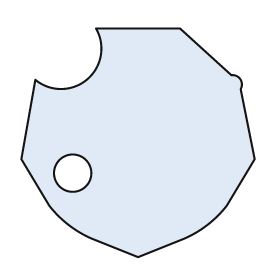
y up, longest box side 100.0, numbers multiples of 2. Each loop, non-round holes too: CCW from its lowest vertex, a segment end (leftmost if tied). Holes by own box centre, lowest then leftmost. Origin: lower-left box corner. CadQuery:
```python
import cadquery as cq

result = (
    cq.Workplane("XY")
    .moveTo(50.0, 0.0)
    .lineTo(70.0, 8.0)
    .threePointArc((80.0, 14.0), (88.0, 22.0))
    .lineTo(100.0, 42.0)
    .lineTo(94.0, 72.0)
    .threePointArc((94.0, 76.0), (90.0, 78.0))
    .lineTo(68.0, 98.0)
    .lineTo(32.0, 98.0)
    .threePointArc((28.0, 76.0), (6.0, 76.0))
    .lineTo(0.0, 42.0)
    .lineTo(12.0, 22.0)
    .threePointArc((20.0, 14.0), (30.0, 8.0))
    .close()
    .moveTo(22.0, 36.0)
    .circle(8.0)
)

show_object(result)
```